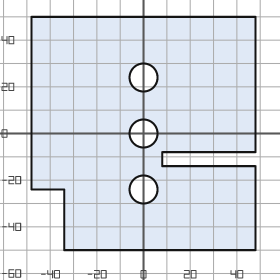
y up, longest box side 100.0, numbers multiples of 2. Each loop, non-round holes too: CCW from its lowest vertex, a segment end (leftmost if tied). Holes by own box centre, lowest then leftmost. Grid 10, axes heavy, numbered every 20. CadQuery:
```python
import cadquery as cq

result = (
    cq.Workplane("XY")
    .moveTo(-34.0, -50.0)
    .lineTo(48.0, -50.0)
    .lineTo(48.0, -14.0)
    .lineTo(8.0, -14.0)
    .lineTo(8.0, -8.0)
    .lineTo(48.0, -8.0)
    .lineTo(48.0, 50.0)
    .lineTo(-48.0, 50.0)
    .lineTo(-48.0, -24.0)
    .lineTo(-34.0, -24.0)
    .close()
    .moveTo(0.0, -24.0)
    .circle(6.0)
    .moveTo(0.0, 0.0)
    .circle(6.0)
    .moveTo(0.0, 24.0)
    .circle(6.0)
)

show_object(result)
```